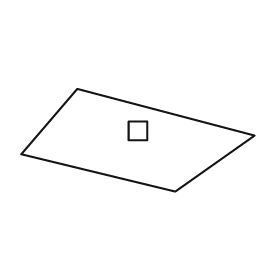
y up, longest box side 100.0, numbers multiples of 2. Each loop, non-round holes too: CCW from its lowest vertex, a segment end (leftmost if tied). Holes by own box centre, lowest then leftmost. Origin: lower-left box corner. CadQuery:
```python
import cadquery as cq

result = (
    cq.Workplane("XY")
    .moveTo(66.0, 0.0)
    .lineTo(100.0, 24.0)
    .lineTo(24.0, 44.0)
    .lineTo(0.0, 16.0)
    .close()
    .moveTo(46.0, 22.0)
    .lineTo(54.0, 22.0)
    .lineTo(54.0, 30.0)
    .lineTo(46.0, 30.0)
    .close()
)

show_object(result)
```